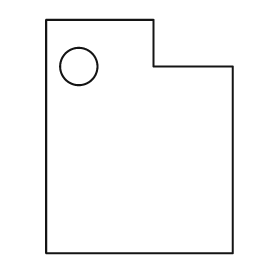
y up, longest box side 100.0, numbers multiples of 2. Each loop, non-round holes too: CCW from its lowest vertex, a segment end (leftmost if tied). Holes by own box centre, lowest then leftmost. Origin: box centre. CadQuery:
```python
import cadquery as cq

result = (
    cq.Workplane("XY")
    .moveTo(-40.0, -50.0)
    .lineTo(40.0, -50.0)
    .lineTo(40.0, 30.0)
    .lineTo(6.0, 30.0)
    .lineTo(6.0, 50.0)
    .lineTo(-40.0, 50.0)
    .close()
    .moveTo(-26.0, 30.0)
    .circle(8.0)
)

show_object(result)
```